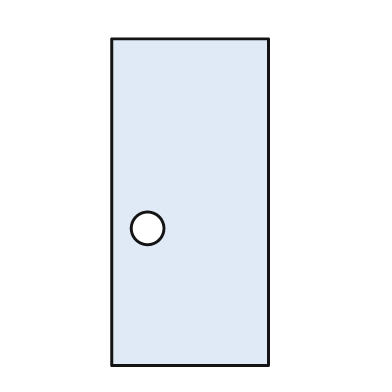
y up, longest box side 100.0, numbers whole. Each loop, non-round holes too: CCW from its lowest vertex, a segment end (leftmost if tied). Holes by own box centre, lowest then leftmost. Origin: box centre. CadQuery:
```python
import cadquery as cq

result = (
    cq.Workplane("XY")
    .moveTo(-24.0, -50.0)
    .lineTo(24.0, -50.0)
    .lineTo(24.0, 50.0)
    .lineTo(-24.0, 50.0)
    .close()
    .moveTo(-13.0, -8.0)
    .circle(5.0)
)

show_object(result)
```